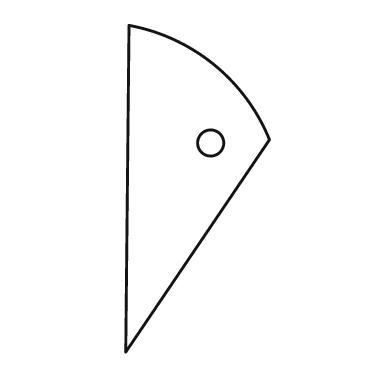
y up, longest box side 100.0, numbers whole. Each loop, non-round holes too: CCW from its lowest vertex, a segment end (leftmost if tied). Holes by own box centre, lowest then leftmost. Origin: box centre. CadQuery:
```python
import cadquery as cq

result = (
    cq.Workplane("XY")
    .moveTo(-22.0, -50.0)
    .lineTo(22.0, 15.0)
    .threePointArc((5.0, 38.0), (-21.0, 50.0))
    .close()
    .moveTo(4.0, 14.0)
    .circle(4.0)
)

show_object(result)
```